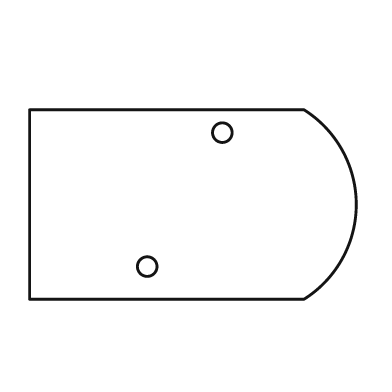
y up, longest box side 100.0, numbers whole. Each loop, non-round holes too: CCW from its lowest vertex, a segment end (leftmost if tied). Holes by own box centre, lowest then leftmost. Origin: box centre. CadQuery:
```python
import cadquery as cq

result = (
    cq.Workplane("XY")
    .moveTo(-50.0, -29.0)
    .lineTo(34.0, -29.0)
    .threePointArc((50.0, 0.0), (34.0, 29.0))
    .lineTo(-50.0, 29.0)
    .close()
    .moveTo(-14.0, -19.0)
    .circle(3.0)
    .moveTo(9.0, 22.0)
    .circle(3.0)
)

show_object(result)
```